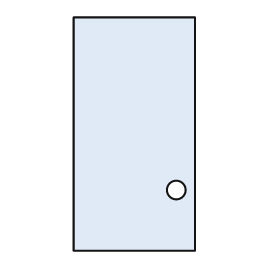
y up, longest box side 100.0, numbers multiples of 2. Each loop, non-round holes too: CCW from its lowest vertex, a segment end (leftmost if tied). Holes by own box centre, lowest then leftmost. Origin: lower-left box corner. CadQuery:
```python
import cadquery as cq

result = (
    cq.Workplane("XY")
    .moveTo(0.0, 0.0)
    .lineTo(52.0, 0.0)
    .lineTo(52.0, 100.0)
    .lineTo(0.0, 100.0)
    .close()
    .moveTo(44.0, 26.0)
    .circle(4.0)
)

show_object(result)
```